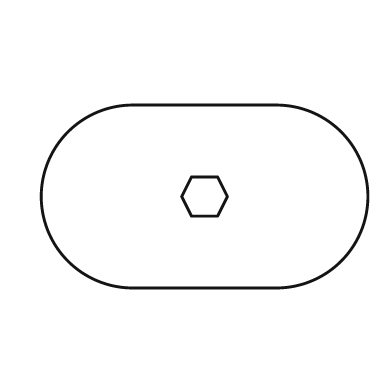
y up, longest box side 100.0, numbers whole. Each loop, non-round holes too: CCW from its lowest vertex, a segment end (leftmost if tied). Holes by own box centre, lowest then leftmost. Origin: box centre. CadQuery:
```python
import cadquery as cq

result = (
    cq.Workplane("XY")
    .moveTo(-22.0, -28.0)
    .lineTo(22.0, -28.0)
    .threePointArc((50.0, 0.0), (22.0, 28.0))
    .lineTo(-22.0, 28.0)
    .threePointArc((-50.0, 0.0), (-22.0, -28.0))
    .close()
    .moveTo(-4.0, -6.0)
    .lineTo(4.0, -6.0)
    .lineTo(7.0, 0.0)
    .lineTo(4.0, 6.0)
    .lineTo(-4.0, 6.0)
    .lineTo(-7.0, 0.0)
    .close()
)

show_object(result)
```